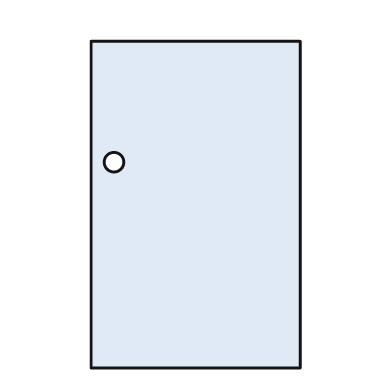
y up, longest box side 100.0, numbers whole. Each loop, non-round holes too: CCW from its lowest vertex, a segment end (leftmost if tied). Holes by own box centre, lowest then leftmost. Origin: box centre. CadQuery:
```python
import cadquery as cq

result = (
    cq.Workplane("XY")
    .moveTo(-32.0, -50.0)
    .lineTo(32.0, -50.0)
    .lineTo(32.0, 50.0)
    .lineTo(-32.0, 50.0)
    .close()
    .moveTo(-25.0, 13.0)
    .circle(3.0)
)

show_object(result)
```